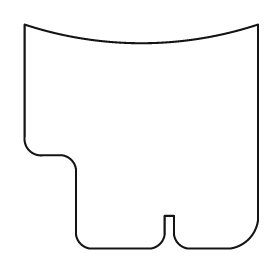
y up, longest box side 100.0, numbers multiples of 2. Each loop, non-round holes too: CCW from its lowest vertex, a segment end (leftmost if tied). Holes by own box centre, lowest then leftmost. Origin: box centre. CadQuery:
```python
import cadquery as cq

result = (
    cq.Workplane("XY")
    .moveTo(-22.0, -48.0)
    .lineTo(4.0, -48.0)
    .threePointArc((8.0, -46.0), (10.0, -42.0))
    .lineTo(10.0, -34.0)
    .lineTo(14.0, -34.0)
    .lineTo(14.0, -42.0)
    .threePointArc((16.0, -46.0), (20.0, -48.0))
    .lineTo(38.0, -48.0)
    .threePointArc((46.0, -44.0), (50.0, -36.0))
    .lineTo(50.0, 48.0)
    .threePointArc((0.0, 40.0), (-50.0, 48.0))
    .lineTo(-50.0, 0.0)
    .threePointArc((-48.0, -6.0), (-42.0, -8.0))
    .lineTo(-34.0, -8.0)
    .threePointArc((-30.0, -10.0), (-28.0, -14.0))
    .lineTo(-28.0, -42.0)
    .threePointArc((-26.0, -46.0), (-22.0, -48.0))
    .close()
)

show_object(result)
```